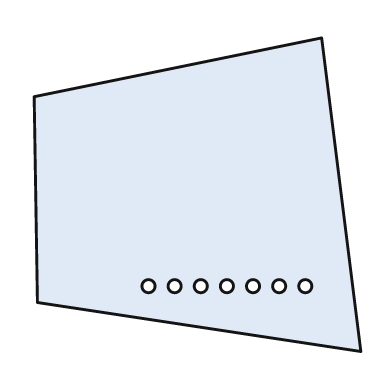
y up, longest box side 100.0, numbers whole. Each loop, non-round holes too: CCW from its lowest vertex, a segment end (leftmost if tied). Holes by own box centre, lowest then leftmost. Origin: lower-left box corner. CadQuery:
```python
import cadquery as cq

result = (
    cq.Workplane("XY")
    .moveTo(100.0, 0.0)
    .lineTo(88.0, 96.0)
    .lineTo(0.0, 78.0)
    .lineTo(1.0, 15.0)
    .close()
    .moveTo(35.0, 20.0)
    .circle(2.0)
    .moveTo(43.0, 20.0)
    .circle(2.0)
    .moveTo(51.0, 20.0)
    .circle(2.0)
    .moveTo(59.0, 20.0)
    .circle(2.0)
    .moveTo(67.0, 20.0)
    .circle(2.0)
    .moveTo(75.0, 20.0)
    .circle(2.0)
    .moveTo(83.0, 20.0)
    .circle(2.0)
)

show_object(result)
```